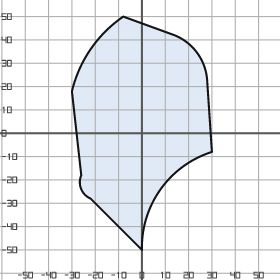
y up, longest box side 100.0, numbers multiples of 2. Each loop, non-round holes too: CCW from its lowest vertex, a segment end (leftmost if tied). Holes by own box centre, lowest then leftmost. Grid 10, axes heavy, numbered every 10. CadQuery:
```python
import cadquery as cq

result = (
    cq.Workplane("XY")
    .moveTo(0.0, -50.0)
    .threePointArc((8.0, -24.0), (30.0, -8.0))
    .lineTo(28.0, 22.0)
    .threePointArc((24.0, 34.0), (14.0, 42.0))
    .lineTo(-8.0, 50.0)
    .threePointArc((-22.0, 36.0), (-30.0, 18.0))
    .lineTo(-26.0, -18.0)
    .threePointArc((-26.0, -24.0), (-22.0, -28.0))
    .close()
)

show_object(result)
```